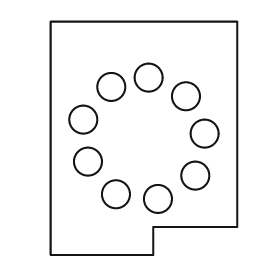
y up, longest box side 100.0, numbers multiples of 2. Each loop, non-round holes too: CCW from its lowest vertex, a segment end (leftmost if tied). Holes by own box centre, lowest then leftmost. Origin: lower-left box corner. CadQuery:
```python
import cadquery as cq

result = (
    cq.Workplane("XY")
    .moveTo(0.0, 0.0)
    .lineTo(44.0, 0.0)
    .lineTo(44.0, 12.0)
    .lineTo(80.0, 12.0)
    .lineTo(80.0, 100.0)
    .lineTo(0.0, 100.0)
    .close()
    .moveTo(46.0, 24.0)
    .circle(6.0)
    .moveTo(28.0, 26.0)
    .circle(6.0)
    .moveTo(62.0, 34.0)
    .circle(6.0)
    .moveTo(16.0, 40.0)
    .circle(6.0)
    .moveTo(66.0, 52.0)
    .circle(6.0)
    .moveTo(14.0, 58.0)
    .circle(6.0)
    .moveTo(58.0, 68.0)
    .circle(6.0)
    .moveTo(26.0, 72.0)
    .circle(6.0)
    .moveTo(42.0, 76.0)
    .circle(6.0)
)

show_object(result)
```